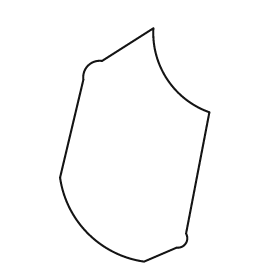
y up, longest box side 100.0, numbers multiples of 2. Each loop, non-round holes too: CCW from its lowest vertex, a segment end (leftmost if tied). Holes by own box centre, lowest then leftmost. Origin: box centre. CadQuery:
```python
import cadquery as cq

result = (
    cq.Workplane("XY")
    .moveTo(4.0, -50.0)
    .lineTo(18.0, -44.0)
    .threePointArc((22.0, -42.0), (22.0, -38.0))
    .lineTo(32.0, 14.0)
    .threePointArc((14.0, 28.0), (8.0, 50.0))
    .lineTo(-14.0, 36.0)
    .threePointArc((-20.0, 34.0), (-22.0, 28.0))
    .lineTo(-32.0, -14.0)
    .threePointArc((-20.0, -38.0), (4.0, -50.0))
    .close()
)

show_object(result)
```